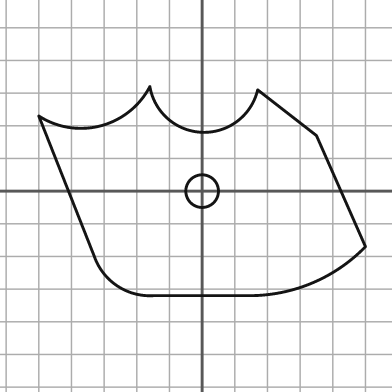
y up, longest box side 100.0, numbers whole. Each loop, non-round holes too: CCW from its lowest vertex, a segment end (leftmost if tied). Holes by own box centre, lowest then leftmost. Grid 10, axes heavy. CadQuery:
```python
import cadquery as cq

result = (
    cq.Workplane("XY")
    .moveTo(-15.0, -32.0)
    .lineTo(15.0, -32.0)
    .threePointArc((34.0, -28.0), (50.0, -17.0))
    .lineTo(35.0, 17.0)
    .lineTo(17.0, 31.0)
    .threePointArc((0.0, 18.0), (-16.0, 32.0))
    .threePointArc((-31.0, 20.0), (-50.0, 23.0))
    .lineTo(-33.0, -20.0)
    .threePointArc((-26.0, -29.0), (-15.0, -32.0))
    .close()
    .moveTo(0.0, 0.0)
    .circle(5.0)
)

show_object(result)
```